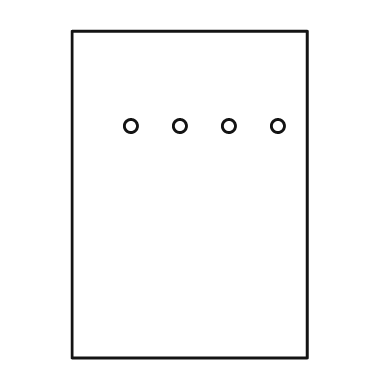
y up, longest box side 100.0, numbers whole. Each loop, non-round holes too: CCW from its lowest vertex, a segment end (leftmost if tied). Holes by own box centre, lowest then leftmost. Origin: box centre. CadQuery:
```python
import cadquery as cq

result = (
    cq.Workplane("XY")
    .moveTo(-36.0, -50.0)
    .lineTo(36.0, -50.0)
    .lineTo(36.0, 50.0)
    .lineTo(-36.0, 50.0)
    .close()
    .moveTo(-18.0, 21.0)
    .circle(2.0)
    .moveTo(-3.0, 21.0)
    .circle(2.0)
    .moveTo(12.0, 21.0)
    .circle(2.0)
    .moveTo(27.0, 21.0)
    .circle(2.0)
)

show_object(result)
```